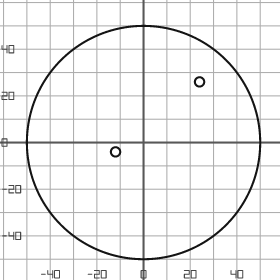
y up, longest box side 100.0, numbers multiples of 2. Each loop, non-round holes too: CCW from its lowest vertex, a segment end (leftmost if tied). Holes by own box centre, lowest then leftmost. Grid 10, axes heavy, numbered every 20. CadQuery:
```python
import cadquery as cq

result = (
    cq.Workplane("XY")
    .moveTo(0.0, 0.0)
    .circle(50.0)
    .moveTo(-12.0, -4.0)
    .circle(2.0)
    .moveTo(24.0, 26.0)
    .circle(2.0)
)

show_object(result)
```